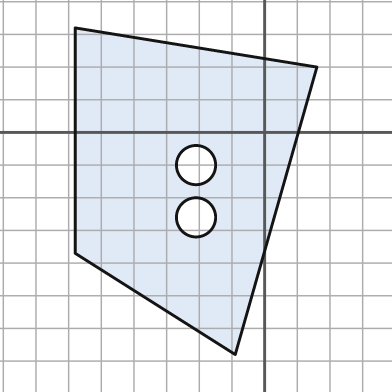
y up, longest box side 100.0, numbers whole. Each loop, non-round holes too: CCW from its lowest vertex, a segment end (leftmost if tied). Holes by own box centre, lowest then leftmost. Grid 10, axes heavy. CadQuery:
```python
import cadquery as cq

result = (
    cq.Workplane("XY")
    .moveTo(-9.0, -68.0)
    .lineTo(16.0, 20.0)
    .lineTo(-58.0, 32.0)
    .lineTo(-58.0, -37.0)
    .close()
    .moveTo(-21.0, -26.0)
    .circle(6.0)
    .moveTo(-21.0, -10.0)
    .circle(6.0)
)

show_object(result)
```